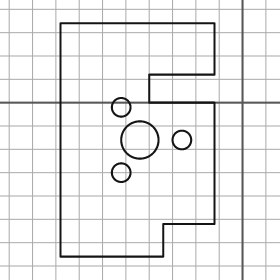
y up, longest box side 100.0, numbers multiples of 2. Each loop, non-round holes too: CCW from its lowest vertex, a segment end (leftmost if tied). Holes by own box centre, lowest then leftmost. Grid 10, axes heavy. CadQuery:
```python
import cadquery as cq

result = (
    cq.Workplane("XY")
    .moveTo(-78.0, -66.0)
    .lineTo(-34.0, -66.0)
    .lineTo(-34.0, -52.0)
    .lineTo(-12.0, -52.0)
    .lineTo(-12.0, 0.0)
    .lineTo(-40.0, 0.0)
    .lineTo(-40.0, 12.0)
    .lineTo(-12.0, 12.0)
    .lineTo(-12.0, 34.0)
    .lineTo(-78.0, 34.0)
    .close()
    .moveTo(-52.0, -30.0)
    .circle(4.0)
    .moveTo(-44.0, -16.0)
    .circle(8.0)
    .moveTo(-26.0, -16.0)
    .circle(4.0)
    .moveTo(-52.0, -2.0)
    .circle(4.0)
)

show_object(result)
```